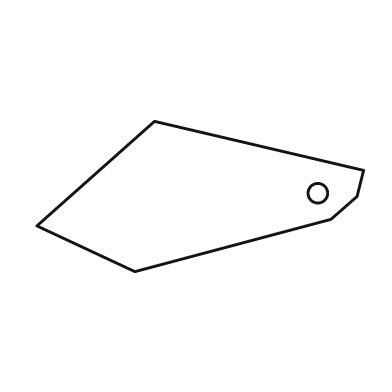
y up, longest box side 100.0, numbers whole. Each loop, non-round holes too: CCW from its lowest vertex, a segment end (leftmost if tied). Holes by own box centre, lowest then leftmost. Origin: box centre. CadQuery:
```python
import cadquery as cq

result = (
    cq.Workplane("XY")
    .moveTo(-20.0, -23.0)
    .lineTo(40.0, -7.0)
    .lineTo(48.0, 0.0)
    .lineTo(50.0, 8.0)
    .lineTo(-14.0, 23.0)
    .lineTo(-50.0, -9.0)
    .close()
    .moveTo(36.0, 1.0)
    .circle(3.0)
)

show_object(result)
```